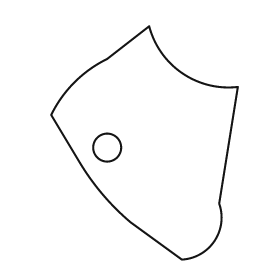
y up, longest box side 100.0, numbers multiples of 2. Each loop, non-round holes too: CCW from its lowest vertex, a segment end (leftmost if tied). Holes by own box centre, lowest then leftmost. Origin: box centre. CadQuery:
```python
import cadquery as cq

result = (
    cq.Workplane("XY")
    .moveTo(16.0, -50.0)
    .threePointArc((30.0, -42.0), (32.0, -26.0))
    .lineTo(40.0, 24.0)
    .threePointArc((16.0, 30.0), (2.0, 50.0))
    .lineTo(-16.0, 36.0)
    .threePointArc((-30.0, 26.0), (-40.0, 12.0))
    .lineTo(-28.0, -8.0)
    .threePointArc((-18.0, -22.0), (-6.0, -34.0))
    .close()
    .moveTo(-16.0, -2.0)
    .circle(6.0)
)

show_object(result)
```